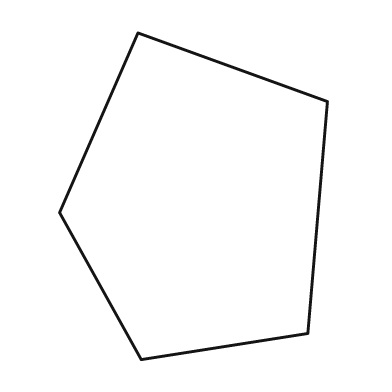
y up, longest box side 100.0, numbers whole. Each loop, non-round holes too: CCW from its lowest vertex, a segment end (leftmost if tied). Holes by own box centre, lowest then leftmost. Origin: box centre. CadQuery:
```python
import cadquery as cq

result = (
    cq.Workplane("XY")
    .moveTo(-16.0, -50.0)
    .lineTo(35.0, -42.0)
    .lineTo(41.0, 29.0)
    .lineTo(-17.0, 50.0)
    .lineTo(-41.0, -5.0)
    .close()
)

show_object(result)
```